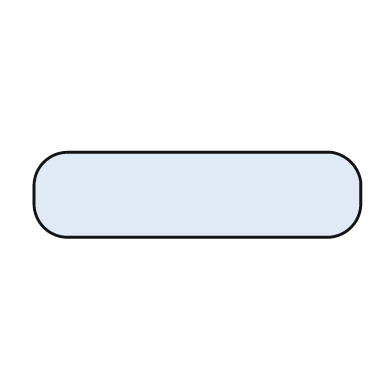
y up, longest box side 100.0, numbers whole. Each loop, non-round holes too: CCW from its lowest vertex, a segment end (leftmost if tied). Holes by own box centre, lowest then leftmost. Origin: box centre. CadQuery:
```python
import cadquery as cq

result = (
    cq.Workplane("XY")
    .moveTo(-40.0, -13.0)
    .lineTo(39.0, -13.0)
    .threePointArc((47.0, -10.0), (50.0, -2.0))
    .lineTo(50.0, 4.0)
    .threePointArc((47.0, 10.0), (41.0, 13.0))
    .lineTo(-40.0, 13.0)
    .threePointArc((-47.0, 10.0), (-50.0, 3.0))
    .lineTo(-50.0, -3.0)
    .threePointArc((-47.0, -10.0), (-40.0, -13.0))
    .close()
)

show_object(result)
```